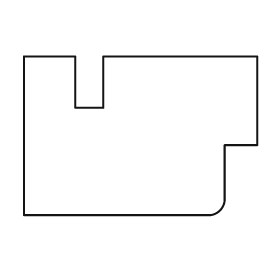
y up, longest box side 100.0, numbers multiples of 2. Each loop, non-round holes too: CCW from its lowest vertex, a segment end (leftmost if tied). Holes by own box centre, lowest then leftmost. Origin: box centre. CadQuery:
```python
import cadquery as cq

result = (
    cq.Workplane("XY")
    .moveTo(-50.0, -34.0)
    .lineTo(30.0, -34.0)
    .threePointArc((34.0, -32.0), (36.0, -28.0))
    .lineTo(36.0, -4.0)
    .lineTo(50.0, -4.0)
    .lineTo(50.0, 34.0)
    .lineTo(-16.0, 34.0)
    .lineTo(-16.0, 12.0)
    .lineTo(-28.0, 12.0)
    .lineTo(-28.0, 34.0)
    .lineTo(-50.0, 34.0)
    .close()
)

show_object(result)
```